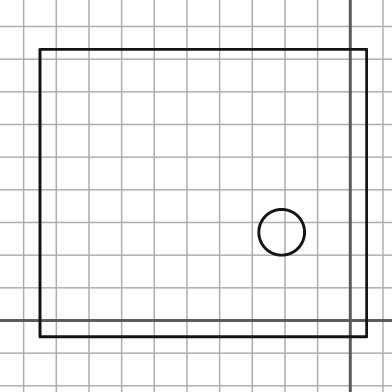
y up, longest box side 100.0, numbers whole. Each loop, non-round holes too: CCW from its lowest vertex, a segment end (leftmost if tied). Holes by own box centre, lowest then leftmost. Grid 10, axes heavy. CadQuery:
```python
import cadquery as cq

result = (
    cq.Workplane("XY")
    .moveTo(-95.0, -5.0)
    .lineTo(5.0, -5.0)
    .lineTo(5.0, 83.0)
    .lineTo(-95.0, 83.0)
    .close()
    .moveTo(-21.0, 27.0)
    .circle(7.0)
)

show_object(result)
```